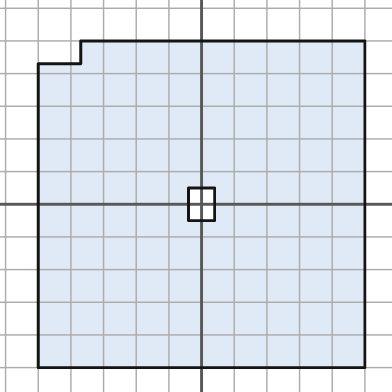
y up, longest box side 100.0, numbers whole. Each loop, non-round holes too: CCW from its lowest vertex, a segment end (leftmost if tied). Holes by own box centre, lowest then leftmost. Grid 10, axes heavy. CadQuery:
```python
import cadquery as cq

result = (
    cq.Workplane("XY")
    .moveTo(-50.0, -50.0)
    .lineTo(50.0, -50.0)
    .lineTo(50.0, 50.0)
    .lineTo(-37.0, 50.0)
    .lineTo(-37.0, 43.0)
    .lineTo(-50.0, 43.0)
    .close()
    .moveTo(-4.0, -5.0)
    .lineTo(4.0, -5.0)
    .lineTo(4.0, 5.0)
    .lineTo(-4.0, 5.0)
    .close()
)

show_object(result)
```